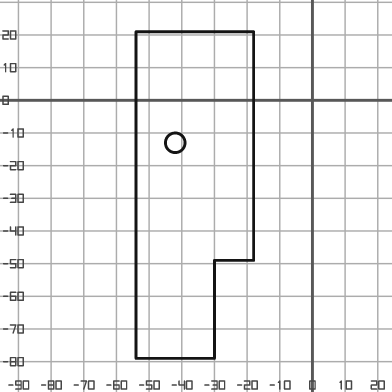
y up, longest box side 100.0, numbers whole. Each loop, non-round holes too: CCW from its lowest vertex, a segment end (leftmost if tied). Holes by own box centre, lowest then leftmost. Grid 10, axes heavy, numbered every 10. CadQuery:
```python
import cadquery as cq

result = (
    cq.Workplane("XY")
    .moveTo(-54.0, -79.0)
    .lineTo(-30.0, -79.0)
    .lineTo(-30.0, -49.0)
    .lineTo(-18.0, -49.0)
    .lineTo(-18.0, 21.0)
    .lineTo(-54.0, 21.0)
    .close()
    .moveTo(-42.0, -13.0)
    .circle(3.0)
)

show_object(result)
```